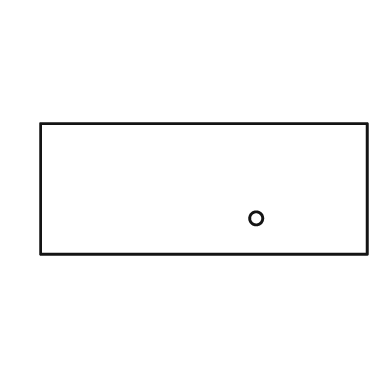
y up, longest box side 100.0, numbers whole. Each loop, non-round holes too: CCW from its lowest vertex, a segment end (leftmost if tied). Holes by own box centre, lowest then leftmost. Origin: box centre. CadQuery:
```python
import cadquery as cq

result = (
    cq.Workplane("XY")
    .moveTo(-50.0, -20.0)
    .lineTo(50.0, -20.0)
    .lineTo(50.0, 20.0)
    .lineTo(-50.0, 20.0)
    .close()
    .moveTo(16.0, -9.0)
    .circle(2.0)
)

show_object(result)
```